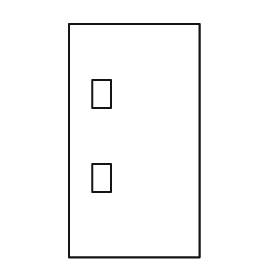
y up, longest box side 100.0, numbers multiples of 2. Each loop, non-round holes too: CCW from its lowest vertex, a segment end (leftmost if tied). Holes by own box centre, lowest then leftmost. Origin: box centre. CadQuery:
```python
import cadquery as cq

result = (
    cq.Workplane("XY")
    .moveTo(-28.0, -50.0)
    .lineTo(28.0, -50.0)
    .lineTo(28.0, 50.0)
    .lineTo(-28.0, 50.0)
    .close()
    .moveTo(-18.0, -22.0)
    .lineTo(-10.0, -22.0)
    .lineTo(-10.0, -10.0)
    .lineTo(-18.0, -10.0)
    .close()
    .moveTo(-18.0, 14.0)
    .lineTo(-10.0, 14.0)
    .lineTo(-10.0, 26.0)
    .lineTo(-18.0, 26.0)
    .close()
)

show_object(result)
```